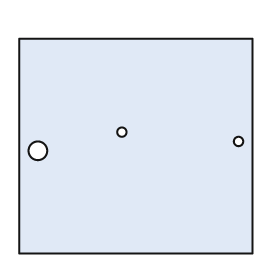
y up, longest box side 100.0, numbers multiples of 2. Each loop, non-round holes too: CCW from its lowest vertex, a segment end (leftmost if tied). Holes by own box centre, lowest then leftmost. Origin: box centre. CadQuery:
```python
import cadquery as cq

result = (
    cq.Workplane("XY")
    .moveTo(-50.0, -46.0)
    .lineTo(50.0, -46.0)
    .lineTo(50.0, 46.0)
    .lineTo(-50.0, 46.0)
    .close()
    .moveTo(-42.0, -2.0)
    .circle(4.0)
    .moveTo(44.0, 2.0)
    .circle(2.0)
    .moveTo(-6.0, 6.0)
    .circle(2.0)
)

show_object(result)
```